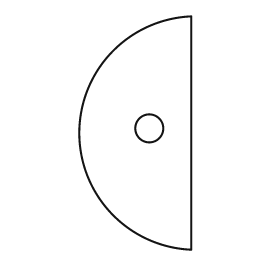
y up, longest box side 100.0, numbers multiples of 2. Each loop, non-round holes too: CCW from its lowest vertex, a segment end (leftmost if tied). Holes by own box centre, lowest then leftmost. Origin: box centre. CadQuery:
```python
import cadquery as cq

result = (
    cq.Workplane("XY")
    .moveTo(24.0, -50.0)
    .lineTo(24.0, 50.0)
    .threePointArc((-24.0, 0.0), (24.0, -50.0))
    .close()
    .moveTo(6.0, 2.0)
    .circle(6.0)
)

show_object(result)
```